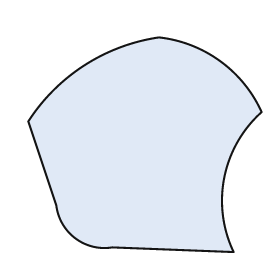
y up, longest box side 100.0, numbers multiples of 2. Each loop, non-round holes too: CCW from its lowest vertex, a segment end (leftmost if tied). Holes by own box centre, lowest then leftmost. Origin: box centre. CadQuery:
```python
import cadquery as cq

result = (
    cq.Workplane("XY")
    .moveTo(38.0, -46.0)
    .threePointArc((34.0, -14.0), (50.0, 14.0))
    .threePointArc((32.0, 36.0), (6.0, 46.0))
    .threePointArc((-26.0, 34.0), (-50.0, 10.0))
    .lineTo(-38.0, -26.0)
    .threePointArc((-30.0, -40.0), (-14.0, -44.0))
    .close()
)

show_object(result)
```